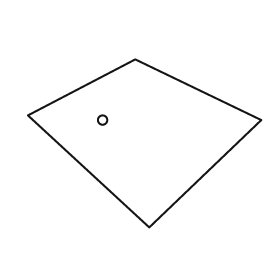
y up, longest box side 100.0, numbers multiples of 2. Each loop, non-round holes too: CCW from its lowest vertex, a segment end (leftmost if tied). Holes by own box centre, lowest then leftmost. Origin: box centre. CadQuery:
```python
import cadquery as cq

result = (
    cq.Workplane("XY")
    .moveTo(2.0, -36.0)
    .lineTo(50.0, 10.0)
    .lineTo(-4.0, 36.0)
    .lineTo(-50.0, 12.0)
    .close()
    .moveTo(-18.0, 10.0)
    .circle(2.0)
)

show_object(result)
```